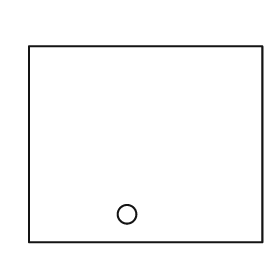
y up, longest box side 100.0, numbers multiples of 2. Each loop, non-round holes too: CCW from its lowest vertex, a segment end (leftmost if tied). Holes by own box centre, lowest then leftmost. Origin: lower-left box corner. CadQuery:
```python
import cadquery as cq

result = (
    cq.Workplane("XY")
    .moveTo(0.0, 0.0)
    .lineTo(100.0, 0.0)
    .lineTo(100.0, 84.0)
    .lineTo(0.0, 84.0)
    .close()
    .moveTo(42.0, 12.0)
    .circle(4.0)
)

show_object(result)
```